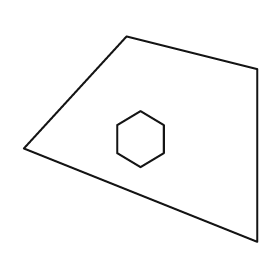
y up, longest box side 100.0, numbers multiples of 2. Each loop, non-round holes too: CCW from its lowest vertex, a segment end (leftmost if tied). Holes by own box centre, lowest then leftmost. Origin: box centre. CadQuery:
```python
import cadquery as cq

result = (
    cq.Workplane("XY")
    .moveTo(50.0, -44.0)
    .lineTo(50.0, 30.0)
    .lineTo(-6.0, 44.0)
    .lineTo(-50.0, -4.0)
    .close()
    .moveTo(0.0, -12.0)
    .lineTo(10.0, -6.0)
    .lineTo(10.0, 6.0)
    .lineTo(0.0, 12.0)
    .lineTo(-10.0, 6.0)
    .lineTo(-10.0, -6.0)
    .close()
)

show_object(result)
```